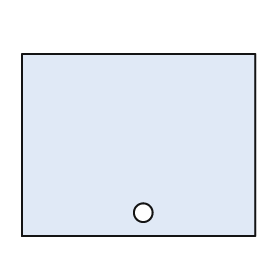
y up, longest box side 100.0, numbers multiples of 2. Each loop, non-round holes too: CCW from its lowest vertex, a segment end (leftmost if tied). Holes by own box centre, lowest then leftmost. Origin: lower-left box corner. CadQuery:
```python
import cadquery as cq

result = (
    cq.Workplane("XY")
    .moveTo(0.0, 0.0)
    .lineTo(100.0, 0.0)
    .lineTo(100.0, 78.0)
    .lineTo(0.0, 78.0)
    .close()
    .moveTo(52.0, 10.0)
    .circle(4.0)
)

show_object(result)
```